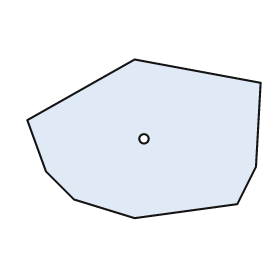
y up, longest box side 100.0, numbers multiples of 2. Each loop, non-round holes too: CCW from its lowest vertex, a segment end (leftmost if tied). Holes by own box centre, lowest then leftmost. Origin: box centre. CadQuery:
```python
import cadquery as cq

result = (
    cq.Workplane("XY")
    .moveTo(-4.0, -34.0)
    .lineTo(40.0, -28.0)
    .lineTo(48.0, -12.0)
    .lineTo(50.0, 24.0)
    .lineTo(-4.0, 34.0)
    .lineTo(-50.0, 8.0)
    .lineTo(-42.0, -14.0)
    .lineTo(-30.0, -26.0)
    .close()
    .moveTo(0.0, 0.0)
    .circle(2.0)
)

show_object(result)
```